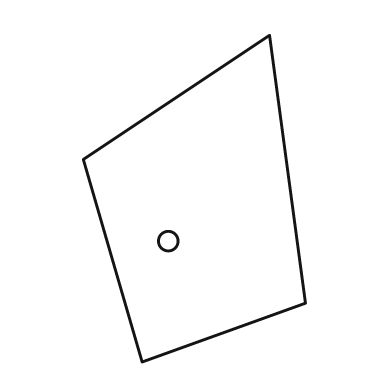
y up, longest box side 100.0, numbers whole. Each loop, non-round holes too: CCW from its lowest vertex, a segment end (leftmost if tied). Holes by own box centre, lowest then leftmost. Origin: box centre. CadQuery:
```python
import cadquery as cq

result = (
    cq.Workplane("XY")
    .moveTo(-16.0, -50.0)
    .lineTo(34.0, -32.0)
    .lineTo(23.0, 50.0)
    .lineTo(-34.0, 12.0)
    .close()
    .moveTo(-8.0, -13.0)
    .circle(3.0)
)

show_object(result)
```